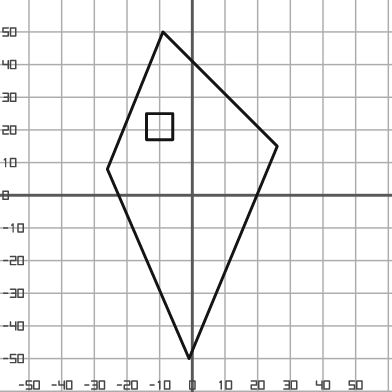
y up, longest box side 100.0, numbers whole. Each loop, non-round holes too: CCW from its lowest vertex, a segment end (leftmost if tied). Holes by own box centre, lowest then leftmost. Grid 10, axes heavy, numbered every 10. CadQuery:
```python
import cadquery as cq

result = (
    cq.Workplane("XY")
    .moveTo(-1.0, -50.0)
    .lineTo(26.0, 15.0)
    .lineTo(-9.0, 50.0)
    .lineTo(-26.0, 8.0)
    .close()
    .moveTo(-14.0, 17.0)
    .lineTo(-6.0, 17.0)
    .lineTo(-6.0, 25.0)
    .lineTo(-14.0, 25.0)
    .close()
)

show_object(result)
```